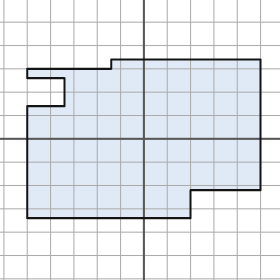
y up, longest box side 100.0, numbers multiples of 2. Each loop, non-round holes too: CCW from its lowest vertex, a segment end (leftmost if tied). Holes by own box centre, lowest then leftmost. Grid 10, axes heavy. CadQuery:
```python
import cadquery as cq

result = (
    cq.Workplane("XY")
    .moveTo(-50.0, -34.0)
    .lineTo(20.0, -34.0)
    .lineTo(20.0, -22.0)
    .lineTo(50.0, -22.0)
    .lineTo(50.0, 34.0)
    .lineTo(-14.0, 34.0)
    .lineTo(-14.0, 30.0)
    .lineTo(-50.0, 30.0)
    .lineTo(-50.0, 26.0)
    .lineTo(-34.0, 26.0)
    .lineTo(-34.0, 14.0)
    .lineTo(-50.0, 14.0)
    .close()
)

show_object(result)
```